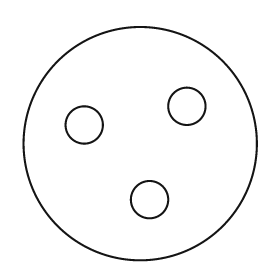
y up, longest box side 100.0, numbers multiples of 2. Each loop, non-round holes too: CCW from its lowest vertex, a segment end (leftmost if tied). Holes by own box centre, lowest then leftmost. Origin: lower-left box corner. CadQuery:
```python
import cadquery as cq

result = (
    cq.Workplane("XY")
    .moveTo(50.0, 50.0)
    .circle(50.0)
    .moveTo(54.0, 26.0)
    .circle(8.0)
    .moveTo(26.0, 58.0)
    .circle(8.0)
    .moveTo(70.0, 66.0)
    .circle(8.0)
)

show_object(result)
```